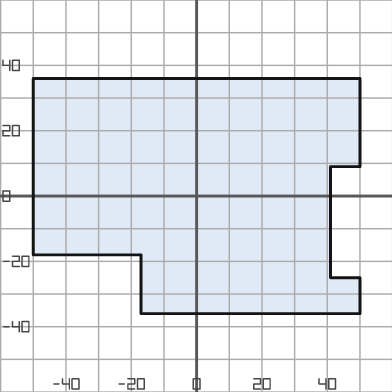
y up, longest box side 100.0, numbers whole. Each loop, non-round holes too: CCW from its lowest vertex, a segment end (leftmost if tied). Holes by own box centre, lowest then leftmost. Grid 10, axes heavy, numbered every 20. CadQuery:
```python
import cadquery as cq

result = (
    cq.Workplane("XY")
    .moveTo(-17.0, -36.0)
    .lineTo(50.0, -36.0)
    .lineTo(50.0, -25.0)
    .lineTo(41.0, -25.0)
    .lineTo(41.0, 9.0)
    .lineTo(50.0, 9.0)
    .lineTo(50.0, 36.0)
    .lineTo(-50.0, 36.0)
    .lineTo(-50.0, -18.0)
    .lineTo(-17.0, -18.0)
    .close()
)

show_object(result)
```